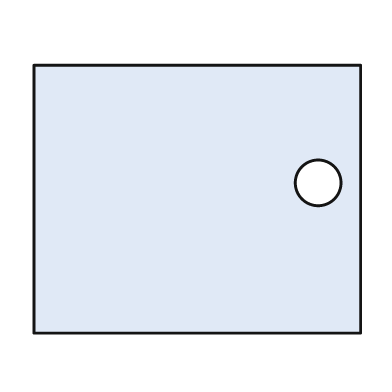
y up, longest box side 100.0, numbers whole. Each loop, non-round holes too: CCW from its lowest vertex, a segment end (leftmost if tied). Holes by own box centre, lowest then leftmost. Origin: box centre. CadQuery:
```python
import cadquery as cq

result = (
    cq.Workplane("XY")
    .moveTo(-50.0, -41.0)
    .lineTo(50.0, -41.0)
    .lineTo(50.0, 41.0)
    .lineTo(-50.0, 41.0)
    .close()
    .moveTo(37.0, 5.0)
    .circle(7.0)
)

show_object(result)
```